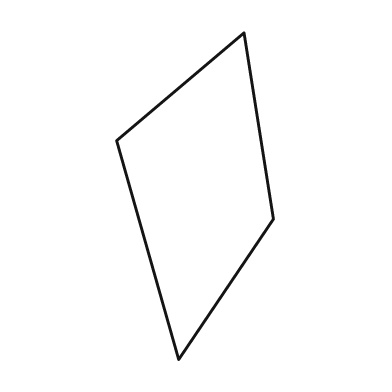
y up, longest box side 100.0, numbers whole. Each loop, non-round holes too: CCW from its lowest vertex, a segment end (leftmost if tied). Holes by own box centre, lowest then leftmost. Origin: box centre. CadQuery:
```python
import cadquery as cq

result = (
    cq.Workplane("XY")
    .moveTo(-5.0, -50.0)
    .lineTo(24.0, -7.0)
    .lineTo(15.0, 50.0)
    .lineTo(-24.0, 17.0)
    .close()
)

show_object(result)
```